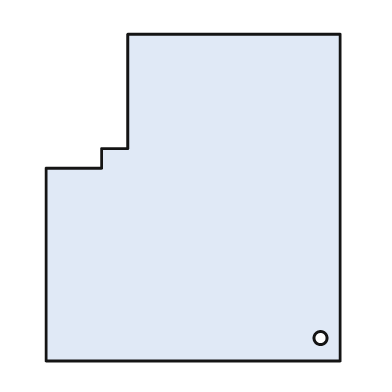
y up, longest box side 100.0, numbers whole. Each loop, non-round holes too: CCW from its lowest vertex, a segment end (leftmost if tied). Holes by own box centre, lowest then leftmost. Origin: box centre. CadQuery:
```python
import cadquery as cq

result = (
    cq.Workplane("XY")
    .moveTo(-45.0, -50.0)
    .lineTo(45.0, -50.0)
    .lineTo(45.0, 50.0)
    .lineTo(-20.0, 50.0)
    .lineTo(-20.0, 15.0)
    .lineTo(-28.0, 15.0)
    .lineTo(-28.0, 9.0)
    .lineTo(-45.0, 9.0)
    .close()
    .moveTo(39.0, -43.0)
    .circle(2.0)
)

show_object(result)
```